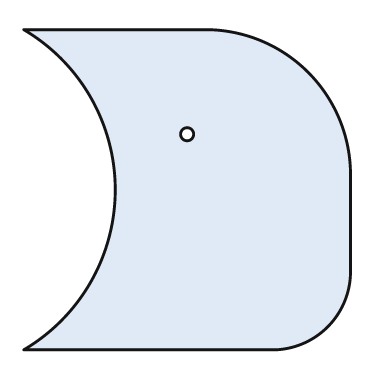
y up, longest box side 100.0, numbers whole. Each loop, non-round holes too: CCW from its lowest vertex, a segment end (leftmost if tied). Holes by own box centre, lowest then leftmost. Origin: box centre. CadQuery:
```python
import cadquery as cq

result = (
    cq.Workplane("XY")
    .moveTo(-50.0, -49.0)
    .lineTo(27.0, -49.0)
    .threePointArc((43.0, -42.0), (50.0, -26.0))
    .lineTo(50.0, 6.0)
    .threePointArc((37.0, 36.0), (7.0, 49.0))
    .lineTo(-50.0, 49.0)
    .threePointArc((-22.0, 0.0), (-50.0, -49.0))
    .close()
    .moveTo(0.0, 17.0)
    .circle(2.0)
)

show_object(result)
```